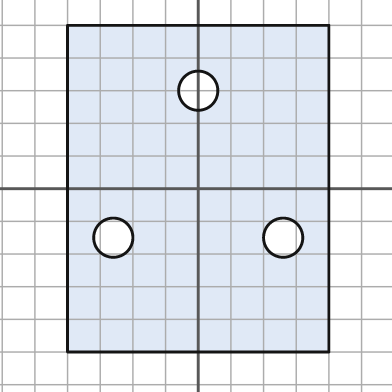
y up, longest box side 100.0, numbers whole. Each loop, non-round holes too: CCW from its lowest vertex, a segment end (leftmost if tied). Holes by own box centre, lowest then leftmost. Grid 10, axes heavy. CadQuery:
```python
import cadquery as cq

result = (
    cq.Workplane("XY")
    .moveTo(-40.0, -50.0)
    .lineTo(40.0, -50.0)
    .lineTo(40.0, 50.0)
    .lineTo(-40.0, 50.0)
    .close()
    .moveTo(-26.0, -15.0)
    .circle(6.0)
    .moveTo(26.0, -15.0)
    .circle(6.0)
    .moveTo(0.0, 30.0)
    .circle(6.0)
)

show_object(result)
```